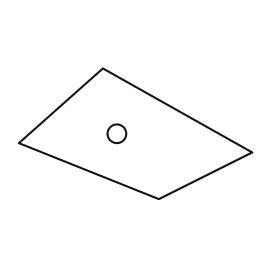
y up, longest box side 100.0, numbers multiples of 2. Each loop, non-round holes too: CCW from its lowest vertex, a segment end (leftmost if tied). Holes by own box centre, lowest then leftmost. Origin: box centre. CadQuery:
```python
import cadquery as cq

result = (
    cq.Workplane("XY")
    .moveTo(10.0, -28.0)
    .lineTo(50.0, -8.0)
    .lineTo(-14.0, 28.0)
    .lineTo(-50.0, -4.0)
    .close()
    .moveTo(-8.0, 0.0)
    .circle(4.0)
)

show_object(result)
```